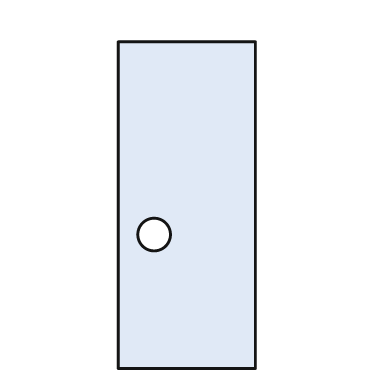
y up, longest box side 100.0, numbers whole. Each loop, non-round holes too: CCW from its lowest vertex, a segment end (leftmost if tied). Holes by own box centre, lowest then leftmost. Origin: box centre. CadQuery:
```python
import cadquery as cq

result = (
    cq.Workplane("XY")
    .moveTo(-21.0, -50.0)
    .lineTo(21.0, -50.0)
    .lineTo(21.0, 50.0)
    .lineTo(-21.0, 50.0)
    .close()
    .moveTo(-10.0, -9.0)
    .circle(5.0)
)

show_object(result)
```